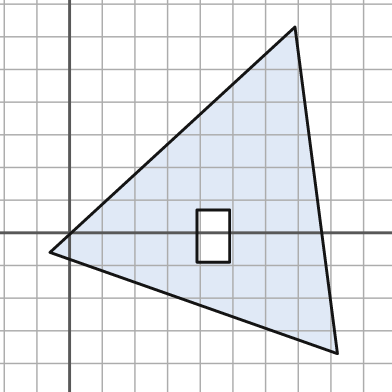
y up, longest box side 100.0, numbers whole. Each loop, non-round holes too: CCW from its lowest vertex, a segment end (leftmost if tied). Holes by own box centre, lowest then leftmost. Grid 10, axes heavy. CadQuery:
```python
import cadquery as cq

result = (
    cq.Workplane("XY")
    .moveTo(82.0, -37.0)
    .lineTo(69.0, 63.0)
    .lineTo(-6.0, -6.0)
    .close()
    .moveTo(39.0, -9.0)
    .lineTo(49.0, -9.0)
    .lineTo(49.0, 7.0)
    .lineTo(39.0, 7.0)
    .close()
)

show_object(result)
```